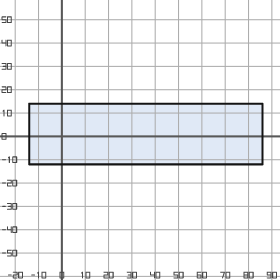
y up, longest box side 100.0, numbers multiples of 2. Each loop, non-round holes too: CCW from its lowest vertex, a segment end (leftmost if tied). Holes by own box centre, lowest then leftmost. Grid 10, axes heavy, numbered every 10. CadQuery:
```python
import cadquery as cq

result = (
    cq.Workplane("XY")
    .moveTo(-14.0, -12.0)
    .lineTo(86.0, -12.0)
    .lineTo(86.0, 14.0)
    .lineTo(-14.0, 14.0)
    .close()
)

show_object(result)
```